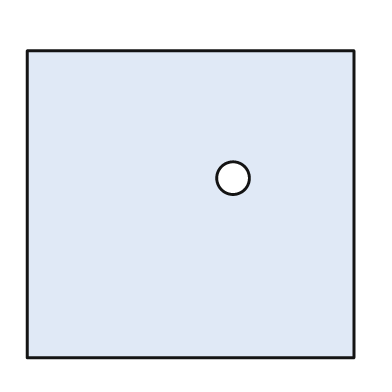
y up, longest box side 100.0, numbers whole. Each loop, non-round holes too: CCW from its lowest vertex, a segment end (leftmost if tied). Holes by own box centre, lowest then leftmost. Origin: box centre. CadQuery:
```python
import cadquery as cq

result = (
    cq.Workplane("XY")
    .moveTo(-50.0, -47.0)
    .lineTo(50.0, -47.0)
    .lineTo(50.0, 47.0)
    .lineTo(-50.0, 47.0)
    .close()
    .moveTo(13.0, 8.0)
    .circle(5.0)
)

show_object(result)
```